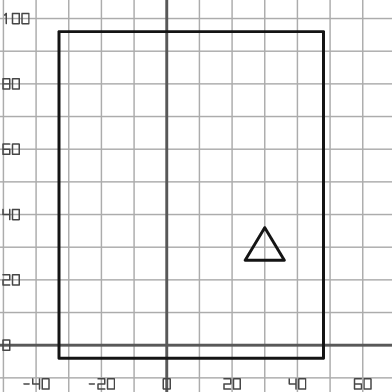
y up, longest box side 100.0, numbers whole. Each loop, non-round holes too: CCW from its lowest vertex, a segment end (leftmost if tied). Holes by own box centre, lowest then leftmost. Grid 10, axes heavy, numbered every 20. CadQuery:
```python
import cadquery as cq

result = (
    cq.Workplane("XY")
    .moveTo(-33.0, -4.0)
    .lineTo(48.0, -4.0)
    .lineTo(48.0, 96.0)
    .lineTo(-33.0, 96.0)
    .close()
    .moveTo(24.0, 26.0)
    .lineTo(36.0, 26.0)
    .lineTo(30.0, 36.0)
    .close()
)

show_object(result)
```